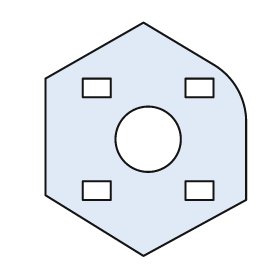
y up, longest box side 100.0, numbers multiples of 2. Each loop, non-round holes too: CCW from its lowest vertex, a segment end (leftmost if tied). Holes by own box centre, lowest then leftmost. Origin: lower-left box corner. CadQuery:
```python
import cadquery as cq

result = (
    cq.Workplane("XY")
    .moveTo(42.0, 0.0)
    .lineTo(86.0, 24.0)
    .lineTo(86.0, 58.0)
    .threePointArc((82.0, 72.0), (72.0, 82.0))
    .lineTo(42.0, 100.0)
    .lineTo(0.0, 76.0)
    .lineTo(0.0, 26.0)
    .close()
    .moveTo(16.0, 24.0)
    .lineTo(28.0, 24.0)
    .lineTo(28.0, 32.0)
    .lineTo(16.0, 32.0)
    .close()
    .moveTo(60.0, 24.0)
    .lineTo(72.0, 24.0)
    .lineTo(72.0, 32.0)
    .lineTo(60.0, 32.0)
    .close()
    .moveTo(44.0, 50.0)
    .circle(14.0)
    .moveTo(16.0, 68.0)
    .lineTo(28.0, 68.0)
    .lineTo(28.0, 76.0)
    .lineTo(16.0, 76.0)
    .close()
    .moveTo(60.0, 68.0)
    .lineTo(72.0, 68.0)
    .lineTo(72.0, 76.0)
    .lineTo(60.0, 76.0)
    .close()
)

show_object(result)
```